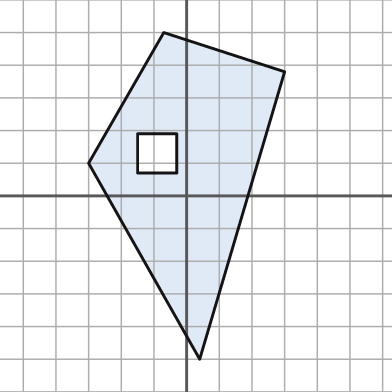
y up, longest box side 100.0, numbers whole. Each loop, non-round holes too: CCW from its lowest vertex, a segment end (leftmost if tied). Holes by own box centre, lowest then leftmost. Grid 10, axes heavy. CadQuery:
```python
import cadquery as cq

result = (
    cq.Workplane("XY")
    .moveTo(4.0, -50.0)
    .lineTo(30.0, 38.0)
    .lineTo(-7.0, 50.0)
    .lineTo(-30.0, 10.0)
    .close()
    .moveTo(-15.0, 7.0)
    .lineTo(-3.0, 7.0)
    .lineTo(-3.0, 19.0)
    .lineTo(-15.0, 19.0)
    .close()
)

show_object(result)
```